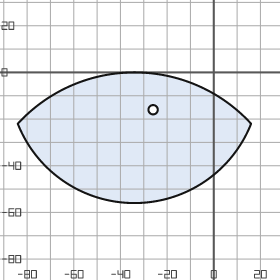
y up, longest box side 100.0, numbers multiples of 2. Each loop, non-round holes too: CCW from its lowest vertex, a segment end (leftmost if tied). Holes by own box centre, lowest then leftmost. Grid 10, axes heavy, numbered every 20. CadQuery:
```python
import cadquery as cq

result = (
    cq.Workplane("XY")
    .moveTo(-84.0, -22.0)
    .threePointArc((-34.0, -56.0), (16.0, -22.0))
    .threePointArc((-34.0, 0.0), (-84.0, -22.0))
    .close()
    .moveTo(-26.0, -16.0)
    .circle(2.0)
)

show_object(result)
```